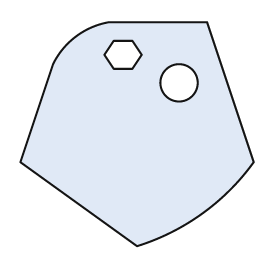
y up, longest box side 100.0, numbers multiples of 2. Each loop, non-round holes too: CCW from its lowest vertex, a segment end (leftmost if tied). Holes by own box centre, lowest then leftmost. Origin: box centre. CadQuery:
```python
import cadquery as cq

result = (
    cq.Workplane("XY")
    .moveTo(0.0, -48.0)
    .threePointArc((28.0, -34.0), (50.0, -12.0))
    .lineTo(30.0, 48.0)
    .lineTo(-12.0, 48.0)
    .threePointArc((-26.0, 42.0), (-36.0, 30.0))
    .lineTo(-50.0, -12.0)
    .close()
    .moveTo(18.0, 22.0)
    .circle(8.0)
    .moveTo(-10.0, 28.0)
    .lineTo(-2.0, 28.0)
    .lineTo(2.0, 34.0)
    .lineTo(-2.0, 40.0)
    .lineTo(-10.0, 40.0)
    .lineTo(-14.0, 34.0)
    .close()
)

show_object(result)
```